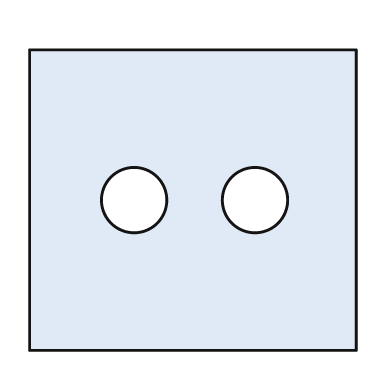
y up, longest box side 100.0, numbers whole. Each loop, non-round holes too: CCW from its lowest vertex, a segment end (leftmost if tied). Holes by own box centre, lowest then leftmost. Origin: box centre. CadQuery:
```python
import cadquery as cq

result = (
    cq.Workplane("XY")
    .moveTo(-50.0, -46.0)
    .lineTo(50.0, -46.0)
    .lineTo(50.0, 46.0)
    .lineTo(-50.0, 46.0)
    .close()
    .moveTo(-18.0, 0.0)
    .circle(10.0)
    .moveTo(19.0, 0.0)
    .circle(10.0)
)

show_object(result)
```